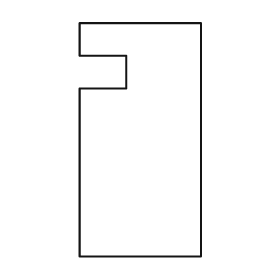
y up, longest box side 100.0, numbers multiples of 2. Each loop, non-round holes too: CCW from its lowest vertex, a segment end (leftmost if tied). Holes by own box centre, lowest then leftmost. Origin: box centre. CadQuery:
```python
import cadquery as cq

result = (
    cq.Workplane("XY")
    .moveTo(-26.0, -50.0)
    .lineTo(26.0, -50.0)
    .lineTo(26.0, 50.0)
    .lineTo(-26.0, 50.0)
    .lineTo(-26.0, 36.0)
    .lineTo(-6.0, 36.0)
    .lineTo(-6.0, 22.0)
    .lineTo(-26.0, 22.0)
    .close()
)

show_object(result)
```